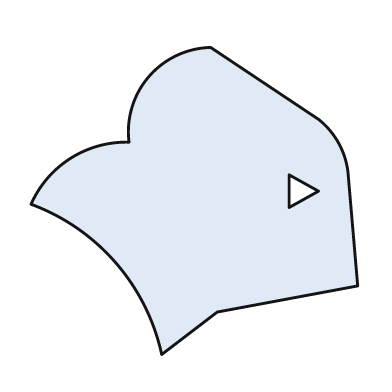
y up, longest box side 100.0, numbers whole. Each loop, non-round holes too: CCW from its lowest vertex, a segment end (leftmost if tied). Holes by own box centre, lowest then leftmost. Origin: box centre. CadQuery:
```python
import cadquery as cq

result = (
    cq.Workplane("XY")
    .moveTo(-10.0, -47.0)
    .lineTo(7.0, -34.0)
    .lineTo(50.0, -26.0)
    .lineTo(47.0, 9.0)
    .threePointArc((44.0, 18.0), (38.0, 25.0))
    .lineTo(5.0, 47.0)
    .threePointArc((-14.0, 38.0), (-20.0, 18.0))
    .threePointArc((-38.0, 13.0), (-50.0, -1.0))
    .threePointArc((-24.0, -19.0), (-10.0, -47.0))
    .close()
    .moveTo(29.0, -2.0)
    .lineTo(38.0, 3.0)
    .lineTo(29.0, 8.0)
    .close()
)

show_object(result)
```